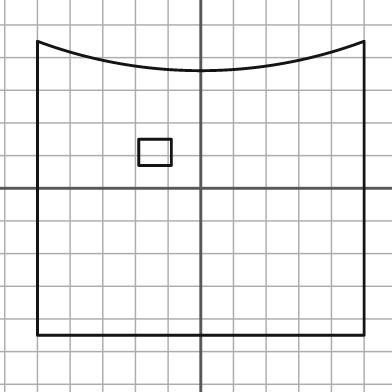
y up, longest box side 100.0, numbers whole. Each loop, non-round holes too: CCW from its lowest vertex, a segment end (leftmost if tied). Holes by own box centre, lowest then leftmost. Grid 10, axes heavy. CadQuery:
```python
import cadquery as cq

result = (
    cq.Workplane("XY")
    .moveTo(-50.0, -45.0)
    .lineTo(50.0, -45.0)
    .lineTo(50.0, 45.0)
    .threePointArc((0.0, 36.0), (-50.0, 45.0))
    .close()
    .moveTo(-19.0, 7.0)
    .lineTo(-9.0, 7.0)
    .lineTo(-9.0, 15.0)
    .lineTo(-19.0, 15.0)
    .close()
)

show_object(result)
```